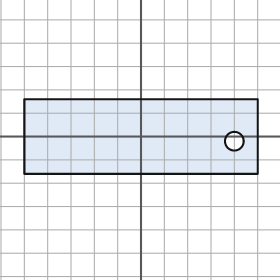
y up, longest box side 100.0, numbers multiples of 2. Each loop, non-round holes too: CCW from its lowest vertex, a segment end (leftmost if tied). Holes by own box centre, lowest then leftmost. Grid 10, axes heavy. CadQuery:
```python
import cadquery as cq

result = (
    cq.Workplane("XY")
    .moveTo(-50.0, -16.0)
    .lineTo(50.0, -16.0)
    .lineTo(50.0, 16.0)
    .lineTo(-50.0, 16.0)
    .close()
    .moveTo(40.0, -2.0)
    .circle(4.0)
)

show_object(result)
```